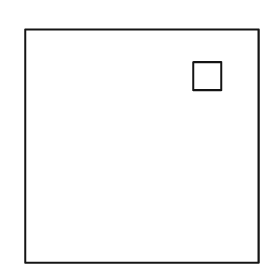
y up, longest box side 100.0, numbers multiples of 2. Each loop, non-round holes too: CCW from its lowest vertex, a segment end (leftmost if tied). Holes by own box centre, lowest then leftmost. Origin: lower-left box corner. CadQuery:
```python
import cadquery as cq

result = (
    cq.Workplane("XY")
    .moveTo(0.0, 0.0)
    .lineTo(100.0, 0.0)
    .lineTo(100.0, 100.0)
    .lineTo(0.0, 100.0)
    .close()
    .moveTo(72.0, 74.0)
    .lineTo(84.0, 74.0)
    .lineTo(84.0, 86.0)
    .lineTo(72.0, 86.0)
    .close()
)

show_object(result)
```